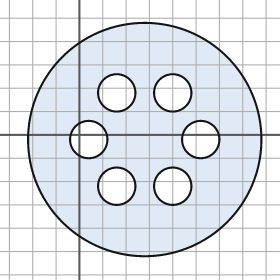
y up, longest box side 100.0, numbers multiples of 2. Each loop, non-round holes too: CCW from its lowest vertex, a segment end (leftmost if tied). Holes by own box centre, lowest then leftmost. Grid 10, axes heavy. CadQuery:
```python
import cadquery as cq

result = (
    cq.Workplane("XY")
    .moveTo(28.0, -2.0)
    .circle(50.0)
    .moveTo(16.0, -22.0)
    .circle(8.0)
    .moveTo(40.0, -22.0)
    .circle(8.0)
    .moveTo(4.0, -2.0)
    .circle(8.0)
    .moveTo(52.0, -2.0)
    .circle(8.0)
    .moveTo(16.0, 18.0)
    .circle(8.0)
    .moveTo(40.0, 18.0)
    .circle(8.0)
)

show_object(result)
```